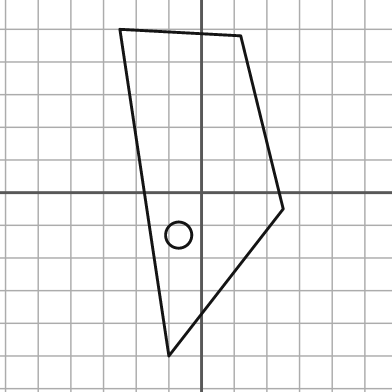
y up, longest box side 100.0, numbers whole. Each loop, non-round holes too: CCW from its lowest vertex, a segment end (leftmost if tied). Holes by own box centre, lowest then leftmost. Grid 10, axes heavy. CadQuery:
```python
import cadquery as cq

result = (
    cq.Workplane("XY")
    .moveTo(-10.0, -50.0)
    .lineTo(25.0, -5.0)
    .lineTo(12.0, 48.0)
    .lineTo(-25.0, 50.0)
    .close()
    .moveTo(-7.0, -13.0)
    .circle(4.0)
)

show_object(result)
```